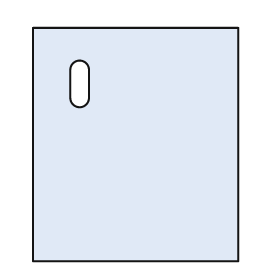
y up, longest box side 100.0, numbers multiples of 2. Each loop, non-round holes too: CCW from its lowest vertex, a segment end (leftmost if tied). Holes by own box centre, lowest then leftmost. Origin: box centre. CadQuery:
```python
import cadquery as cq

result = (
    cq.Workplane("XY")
    .moveTo(-44.0, -50.0)
    .lineTo(44.0, -50.0)
    .lineTo(44.0, 50.0)
    .lineTo(-44.0, 50.0)
    .close()
    .moveTo(-28.0, 20.0)
    .threePointArc((-24.0, 16.0), (-20.0, 20.0))
    .lineTo(-20.0, 32.0)
    .threePointArc((-24.0, 36.0), (-28.0, 32.0))
    .close()
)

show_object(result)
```